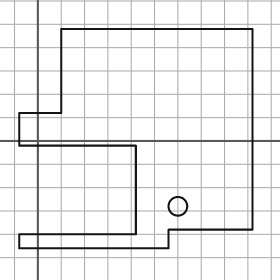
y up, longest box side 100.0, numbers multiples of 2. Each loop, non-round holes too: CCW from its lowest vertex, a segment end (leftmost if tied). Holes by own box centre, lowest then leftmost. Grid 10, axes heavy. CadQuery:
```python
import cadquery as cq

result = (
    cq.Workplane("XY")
    .moveTo(-8.0, -46.0)
    .lineTo(56.0, -46.0)
    .lineTo(56.0, -38.0)
    .lineTo(92.0, -38.0)
    .lineTo(92.0, 48.0)
    .lineTo(10.0, 48.0)
    .lineTo(10.0, 12.0)
    .lineTo(-8.0, 12.0)
    .lineTo(-8.0, -2.0)
    .lineTo(42.0, -2.0)
    .lineTo(42.0, -40.0)
    .lineTo(-8.0, -40.0)
    .close()
    .moveTo(60.0, -28.0)
    .circle(4.0)
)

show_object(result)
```